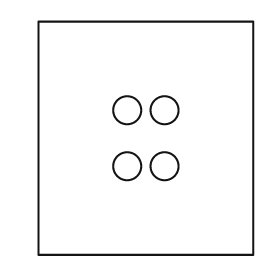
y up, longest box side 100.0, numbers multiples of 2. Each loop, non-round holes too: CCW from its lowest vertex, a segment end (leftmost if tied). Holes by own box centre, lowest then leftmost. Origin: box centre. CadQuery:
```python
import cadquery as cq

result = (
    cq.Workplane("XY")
    .moveTo(-46.0, -50.0)
    .lineTo(46.0, -50.0)
    .lineTo(46.0, 50.0)
    .lineTo(-46.0, 50.0)
    .close()
    .moveTo(-8.0, -12.0)
    .circle(6.0)
    .moveTo(8.0, -12.0)
    .circle(6.0)
    .moveTo(-8.0, 12.0)
    .circle(6.0)
    .moveTo(8.0, 12.0)
    .circle(6.0)
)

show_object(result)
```